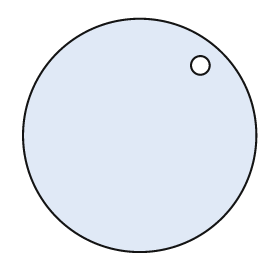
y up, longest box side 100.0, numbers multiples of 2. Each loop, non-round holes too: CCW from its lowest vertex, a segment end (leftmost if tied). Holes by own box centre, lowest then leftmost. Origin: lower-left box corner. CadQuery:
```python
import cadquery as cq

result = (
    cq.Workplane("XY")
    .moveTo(50.0, 50.0)
    .circle(50.0)
    .moveTo(76.0, 80.0)
    .circle(4.0)
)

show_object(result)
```